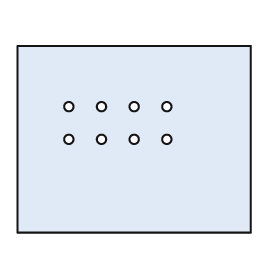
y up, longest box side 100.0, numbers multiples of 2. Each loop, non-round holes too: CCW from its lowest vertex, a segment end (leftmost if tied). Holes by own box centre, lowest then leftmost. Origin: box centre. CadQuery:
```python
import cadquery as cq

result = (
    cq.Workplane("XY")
    .moveTo(-50.0, -40.0)
    .lineTo(50.0, -40.0)
    .lineTo(50.0, 40.0)
    .lineTo(-50.0, 40.0)
    .close()
    .moveTo(-28.0, 0.0)
    .circle(2.0)
    .moveTo(-14.0, 0.0)
    .circle(2.0)
    .moveTo(0.0, 0.0)
    .circle(2.0)
    .moveTo(14.0, 0.0)
    .circle(2.0)
    .moveTo(-28.0, 14.0)
    .circle(2.0)
    .moveTo(-14.0, 14.0)
    .circle(2.0)
    .moveTo(0.0, 14.0)
    .circle(2.0)
    .moveTo(14.0, 14.0)
    .circle(2.0)
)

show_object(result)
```